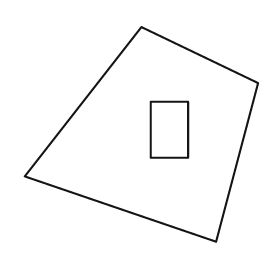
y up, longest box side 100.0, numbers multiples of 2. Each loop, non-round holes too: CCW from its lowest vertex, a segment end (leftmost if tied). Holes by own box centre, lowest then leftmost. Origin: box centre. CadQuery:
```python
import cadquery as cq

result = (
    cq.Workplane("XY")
    .moveTo(32.0, -46.0)
    .lineTo(50.0, 22.0)
    .lineTo(0.0, 46.0)
    .lineTo(-50.0, -18.0)
    .close()
    .moveTo(4.0, -10.0)
    .lineTo(20.0, -10.0)
    .lineTo(20.0, 14.0)
    .lineTo(4.0, 14.0)
    .close()
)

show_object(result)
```